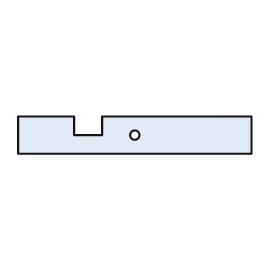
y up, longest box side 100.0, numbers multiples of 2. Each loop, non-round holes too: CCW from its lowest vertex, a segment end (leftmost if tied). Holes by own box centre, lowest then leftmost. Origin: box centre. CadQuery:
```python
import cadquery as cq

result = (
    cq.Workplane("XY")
    .moveTo(-50.0, -8.0)
    .lineTo(50.0, -8.0)
    .lineTo(50.0, 8.0)
    .lineTo(-14.0, 8.0)
    .lineTo(-14.0, 0.0)
    .lineTo(-26.0, 0.0)
    .lineTo(-26.0, 8.0)
    .lineTo(-50.0, 8.0)
    .close()
    .moveTo(0.0, 0.0)
    .circle(2.0)
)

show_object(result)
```